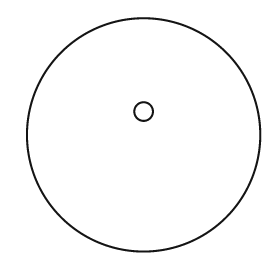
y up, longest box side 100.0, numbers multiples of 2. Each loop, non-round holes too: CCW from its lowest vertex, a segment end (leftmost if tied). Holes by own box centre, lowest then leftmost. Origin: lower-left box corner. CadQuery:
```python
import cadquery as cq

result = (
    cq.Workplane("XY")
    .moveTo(50.0, 50.0)
    .circle(50.0)
    .moveTo(50.0, 60.0)
    .circle(4.0)
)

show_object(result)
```